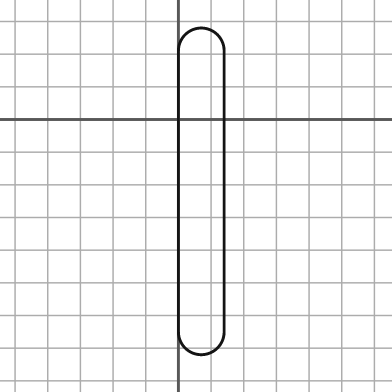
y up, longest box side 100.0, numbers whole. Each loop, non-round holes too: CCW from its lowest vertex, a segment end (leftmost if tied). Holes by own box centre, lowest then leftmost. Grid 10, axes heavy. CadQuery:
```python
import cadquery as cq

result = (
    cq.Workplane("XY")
    .moveTo(0.0, -65.0)
    .threePointArc((7.0, -72.0), (14.0, -65.0))
    .lineTo(14.0, 21.0)
    .threePointArc((7.0, 28.0), (0.0, 21.0))
    .close()
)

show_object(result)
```